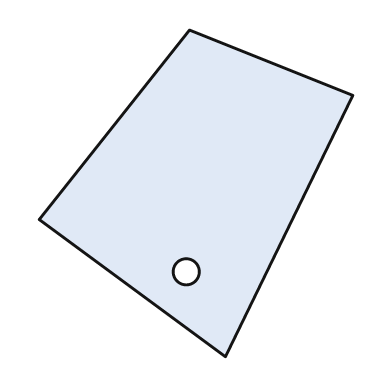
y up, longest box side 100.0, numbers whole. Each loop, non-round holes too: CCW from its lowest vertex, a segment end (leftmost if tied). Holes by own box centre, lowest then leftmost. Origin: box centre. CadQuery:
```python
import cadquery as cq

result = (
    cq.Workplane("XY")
    .moveTo(9.0, -50.0)
    .lineTo(48.0, 30.0)
    .lineTo(-2.0, 50.0)
    .lineTo(-48.0, -8.0)
    .close()
    .moveTo(-3.0, -24.0)
    .circle(4.0)
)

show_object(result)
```